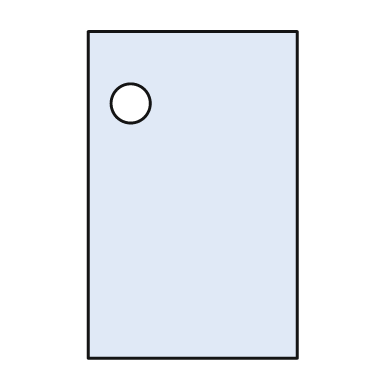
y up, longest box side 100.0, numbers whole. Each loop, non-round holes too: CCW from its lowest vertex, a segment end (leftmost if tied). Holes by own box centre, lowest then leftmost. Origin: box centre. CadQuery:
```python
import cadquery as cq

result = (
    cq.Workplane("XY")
    .moveTo(-32.0, -50.0)
    .lineTo(32.0, -50.0)
    .lineTo(32.0, 50.0)
    .lineTo(-32.0, 50.0)
    .close()
    .moveTo(-19.0, 28.0)
    .circle(6.0)
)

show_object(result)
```